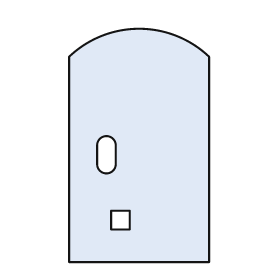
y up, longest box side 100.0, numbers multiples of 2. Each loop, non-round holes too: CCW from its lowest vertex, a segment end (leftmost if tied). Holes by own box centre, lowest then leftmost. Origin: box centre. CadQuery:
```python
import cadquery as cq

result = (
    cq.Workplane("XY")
    .moveTo(-30.0, -50.0)
    .lineTo(30.0, -50.0)
    .lineTo(30.0, 38.0)
    .threePointArc((0.0, 50.0), (-30.0, 38.0))
    .close()
    .moveTo(-12.0, -36.0)
    .lineTo(-4.0, -36.0)
    .lineTo(-4.0, -28.0)
    .lineTo(-12.0, -28.0)
    .close()
    .moveTo(-18.0, -8.0)
    .threePointArc((-14.0, -12.0), (-10.0, -8.0))
    .lineTo(-10.0, 0.0)
    .threePointArc((-14.0, 4.0), (-18.0, 0.0))
    .close()
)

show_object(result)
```